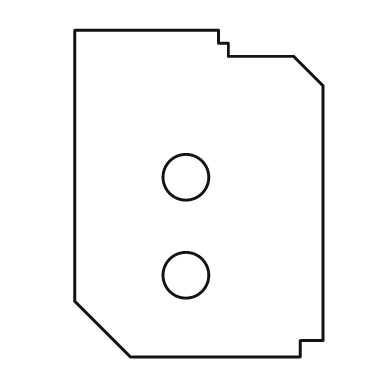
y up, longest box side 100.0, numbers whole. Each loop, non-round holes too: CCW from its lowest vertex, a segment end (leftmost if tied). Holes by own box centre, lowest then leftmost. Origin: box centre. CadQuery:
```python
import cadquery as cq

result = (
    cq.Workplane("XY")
    .moveTo(-21.0, -50.0)
    .lineTo(31.0, -50.0)
    .lineTo(31.0, -45.0)
    .lineTo(38.0, -45.0)
    .lineTo(38.0, 33.0)
    .lineTo(29.0, 42.0)
    .lineTo(9.0, 42.0)
    .lineTo(9.0, 46.0)
    .lineTo(6.0, 46.0)
    .lineTo(6.0, 50.0)
    .lineTo(-38.0, 50.0)
    .lineTo(-38.0, -33.0)
    .close()
    .moveTo(-4.0, -25.0)
    .circle(7.0)
    .moveTo(-4.0, 5.0)
    .circle(7.0)
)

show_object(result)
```